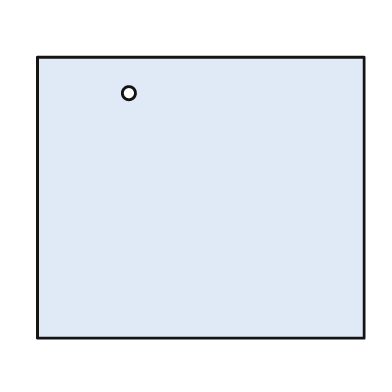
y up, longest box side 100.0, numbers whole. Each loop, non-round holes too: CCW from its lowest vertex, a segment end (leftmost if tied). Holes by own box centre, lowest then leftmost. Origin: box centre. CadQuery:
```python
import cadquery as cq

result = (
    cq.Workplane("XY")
    .moveTo(-50.0, -43.0)
    .lineTo(50.0, -43.0)
    .lineTo(50.0, 43.0)
    .lineTo(-50.0, 43.0)
    .close()
    .moveTo(-22.0, 32.0)
    .circle(2.0)
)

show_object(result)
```